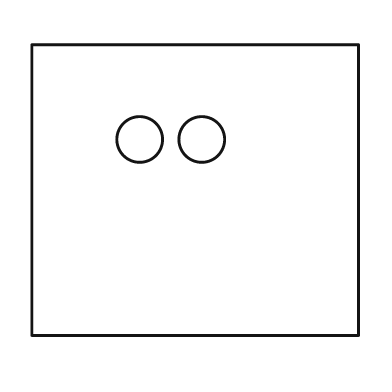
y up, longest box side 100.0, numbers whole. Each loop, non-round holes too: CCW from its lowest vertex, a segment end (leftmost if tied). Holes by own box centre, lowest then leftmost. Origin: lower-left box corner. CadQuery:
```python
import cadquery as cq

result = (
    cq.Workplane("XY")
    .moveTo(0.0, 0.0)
    .lineTo(100.0, 0.0)
    .lineTo(100.0, 89.0)
    .lineTo(0.0, 89.0)
    .close()
    .moveTo(33.0, 60.0)
    .circle(7.0)
    .moveTo(52.0, 60.0)
    .circle(7.0)
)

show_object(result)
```